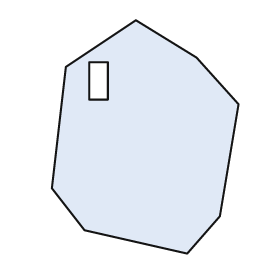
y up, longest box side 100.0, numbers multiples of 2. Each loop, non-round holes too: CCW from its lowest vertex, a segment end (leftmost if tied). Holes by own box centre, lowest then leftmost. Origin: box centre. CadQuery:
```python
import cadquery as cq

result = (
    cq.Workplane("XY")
    .moveTo(18.0, -50.0)
    .lineTo(32.0, -34.0)
    .lineTo(40.0, 14.0)
    .lineTo(22.0, 34.0)
    .lineTo(-4.0, 50.0)
    .lineTo(-34.0, 30.0)
    .lineTo(-40.0, -22.0)
    .lineTo(-26.0, -40.0)
    .close()
    .moveTo(-24.0, 16.0)
    .lineTo(-16.0, 16.0)
    .lineTo(-16.0, 32.0)
    .lineTo(-24.0, 32.0)
    .close()
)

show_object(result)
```